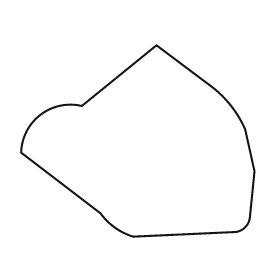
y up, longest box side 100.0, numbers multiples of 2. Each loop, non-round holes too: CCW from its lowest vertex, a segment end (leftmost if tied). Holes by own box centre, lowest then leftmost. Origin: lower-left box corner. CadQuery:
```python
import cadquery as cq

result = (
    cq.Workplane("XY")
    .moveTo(48.0, 0.0)
    .lineTo(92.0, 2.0)
    .threePointArc((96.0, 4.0), (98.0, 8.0))
    .lineTo(100.0, 28.0)
    .lineTo(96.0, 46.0)
    .threePointArc((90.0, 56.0), (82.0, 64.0))
    .lineTo(58.0, 82.0)
    .lineTo(26.0, 56.0)
    .threePointArc((8.0, 52.0), (0.0, 36.0))
    .lineTo(34.0, 10.0)
    .threePointArc((40.0, 4.0), (48.0, 0.0))
    .close()
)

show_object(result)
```